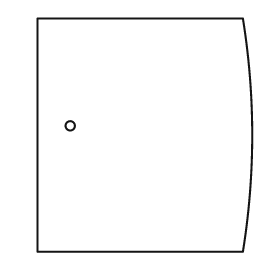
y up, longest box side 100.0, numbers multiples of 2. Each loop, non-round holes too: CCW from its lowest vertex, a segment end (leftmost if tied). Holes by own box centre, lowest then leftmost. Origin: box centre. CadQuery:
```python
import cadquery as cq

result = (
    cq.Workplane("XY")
    .moveTo(-46.0, -50.0)
    .lineTo(42.0, -50.0)
    .threePointArc((46.0, 0.0), (42.0, 50.0))
    .lineTo(-46.0, 50.0)
    .close()
    .moveTo(-32.0, 4.0)
    .circle(2.0)
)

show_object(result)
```